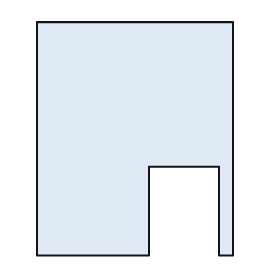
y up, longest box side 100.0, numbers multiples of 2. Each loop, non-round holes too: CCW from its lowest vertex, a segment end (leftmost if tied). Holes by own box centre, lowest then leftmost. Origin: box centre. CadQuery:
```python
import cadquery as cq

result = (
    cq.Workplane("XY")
    .moveTo(-42.0, -50.0)
    .lineTo(6.0, -50.0)
    .lineTo(6.0, -12.0)
    .lineTo(36.0, -12.0)
    .lineTo(36.0, -50.0)
    .lineTo(42.0, -50.0)
    .lineTo(42.0, 50.0)
    .lineTo(-42.0, 50.0)
    .close()
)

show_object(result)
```